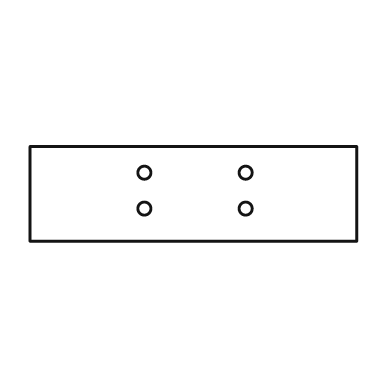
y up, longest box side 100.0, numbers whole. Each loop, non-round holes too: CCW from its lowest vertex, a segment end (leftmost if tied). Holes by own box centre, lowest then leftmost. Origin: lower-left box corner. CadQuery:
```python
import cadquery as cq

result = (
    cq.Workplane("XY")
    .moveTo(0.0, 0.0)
    .lineTo(100.0, 0.0)
    .lineTo(100.0, 29.0)
    .lineTo(0.0, 29.0)
    .close()
    .moveTo(35.0, 10.0)
    .circle(2.0)
    .moveTo(66.0, 10.0)
    .circle(2.0)
    .moveTo(35.0, 21.0)
    .circle(2.0)
    .moveTo(66.0, 21.0)
    .circle(2.0)
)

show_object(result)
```